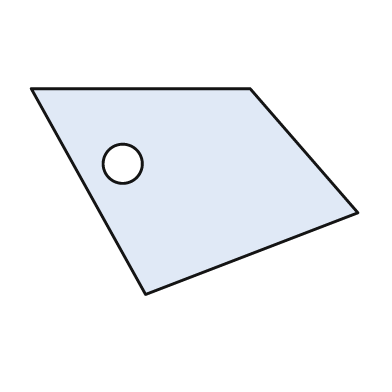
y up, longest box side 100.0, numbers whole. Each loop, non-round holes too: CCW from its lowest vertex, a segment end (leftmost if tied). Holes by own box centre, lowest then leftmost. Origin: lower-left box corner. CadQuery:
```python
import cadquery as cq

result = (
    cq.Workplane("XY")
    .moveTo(35.0, 0.0)
    .lineTo(100.0, 25.0)
    .lineTo(67.0, 63.0)
    .lineTo(0.0, 63.0)
    .close()
    .moveTo(28.0, 40.0)
    .circle(6.0)
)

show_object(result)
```